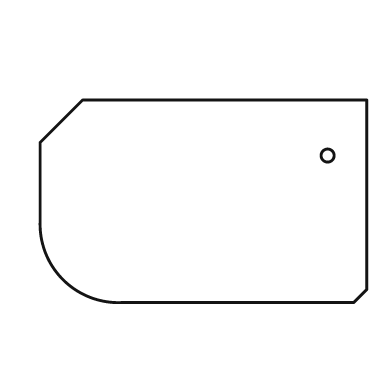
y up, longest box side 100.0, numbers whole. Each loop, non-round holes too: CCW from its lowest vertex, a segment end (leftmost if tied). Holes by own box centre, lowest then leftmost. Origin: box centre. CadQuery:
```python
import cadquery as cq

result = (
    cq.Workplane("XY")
    .moveTo(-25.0, -31.0)
    .lineTo(46.0, -31.0)
    .lineTo(50.0, -27.0)
    .lineTo(50.0, 31.0)
    .lineTo(-37.0, 31.0)
    .lineTo(-50.0, 18.0)
    .lineTo(-50.0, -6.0)
    .threePointArc((-43.0, -24.0), (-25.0, -31.0))
    .close()
    .moveTo(38.0, 14.0)
    .circle(2.0)
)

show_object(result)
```